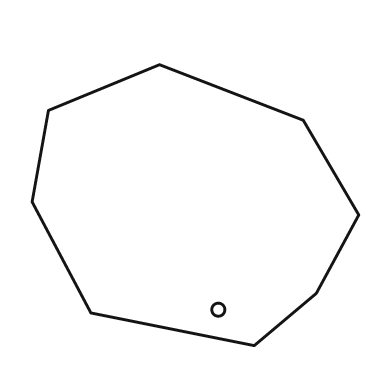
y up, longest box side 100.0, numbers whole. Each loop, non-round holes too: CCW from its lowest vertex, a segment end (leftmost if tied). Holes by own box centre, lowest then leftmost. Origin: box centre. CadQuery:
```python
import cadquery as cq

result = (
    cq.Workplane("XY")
    .moveTo(18.0, -43.0)
    .lineTo(37.0, -27.0)
    .lineTo(50.0, -3.0)
    .lineTo(33.0, 26.0)
    .lineTo(-11.0, 43.0)
    .lineTo(-45.0, 29.0)
    .lineTo(-50.0, 1.0)
    .lineTo(-32.0, -33.0)
    .close()
    .moveTo(7.0, -32.0)
    .circle(2.0)
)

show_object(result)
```